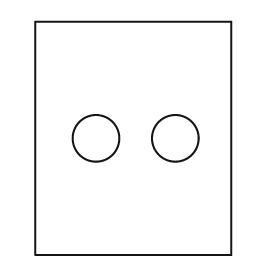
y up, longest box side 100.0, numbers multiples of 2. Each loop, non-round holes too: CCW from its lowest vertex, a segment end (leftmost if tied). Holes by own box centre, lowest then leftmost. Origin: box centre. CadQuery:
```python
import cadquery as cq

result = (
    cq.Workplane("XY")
    .moveTo(-42.0, -50.0)
    .lineTo(42.0, -50.0)
    .lineTo(42.0, 50.0)
    .lineTo(-42.0, 50.0)
    .close()
    .moveTo(-16.0, 0.0)
    .circle(10.0)
    .moveTo(18.0, 0.0)
    .circle(10.0)
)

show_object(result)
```